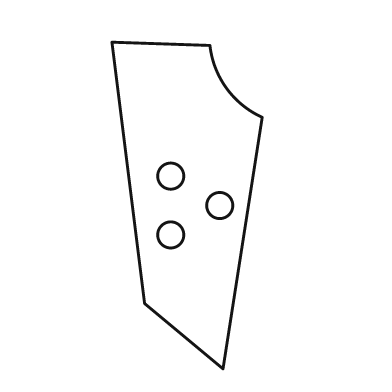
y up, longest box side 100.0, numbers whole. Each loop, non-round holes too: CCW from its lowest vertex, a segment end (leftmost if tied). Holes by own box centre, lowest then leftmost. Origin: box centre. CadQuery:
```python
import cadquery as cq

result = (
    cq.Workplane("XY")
    .moveTo(11.0, -50.0)
    .lineTo(23.0, 27.0)
    .threePointArc((12.0, 36.0), (7.0, 49.0))
    .lineTo(-23.0, 50.0)
    .lineTo(-13.0, -30.0)
    .close()
    .moveTo(-5.0, -9.0)
    .circle(4.0)
    .moveTo(10.0, 0.0)
    .circle(4.0)
    .moveTo(-5.0, 9.0)
    .circle(4.0)
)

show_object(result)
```